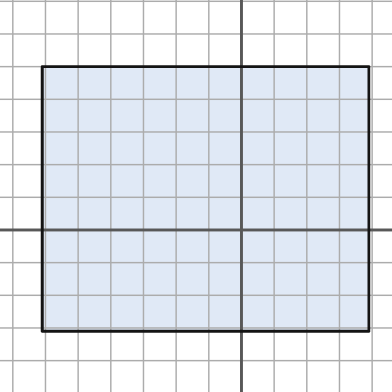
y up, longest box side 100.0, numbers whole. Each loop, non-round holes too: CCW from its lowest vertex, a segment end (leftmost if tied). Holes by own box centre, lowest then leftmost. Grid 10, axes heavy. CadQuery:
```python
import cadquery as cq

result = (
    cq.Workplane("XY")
    .moveTo(-61.0, -31.0)
    .lineTo(39.0, -31.0)
    .lineTo(39.0, 50.0)
    .lineTo(-61.0, 50.0)
    .close()
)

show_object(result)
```